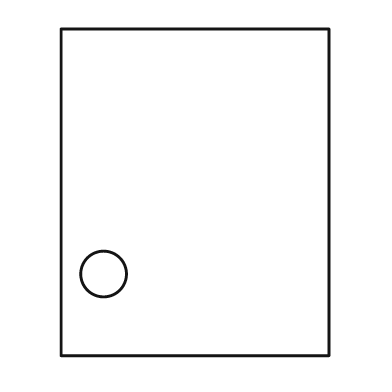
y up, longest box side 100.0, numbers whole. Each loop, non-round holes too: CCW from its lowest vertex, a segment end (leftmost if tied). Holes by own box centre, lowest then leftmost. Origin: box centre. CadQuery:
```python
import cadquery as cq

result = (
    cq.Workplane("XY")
    .moveTo(-41.0, -50.0)
    .lineTo(41.0, -50.0)
    .lineTo(41.0, 50.0)
    .lineTo(-41.0, 50.0)
    .close()
    .moveTo(-28.0, -25.0)
    .circle(7.0)
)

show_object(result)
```